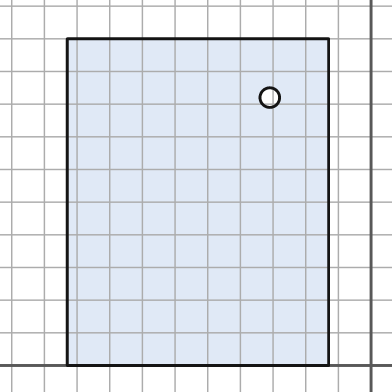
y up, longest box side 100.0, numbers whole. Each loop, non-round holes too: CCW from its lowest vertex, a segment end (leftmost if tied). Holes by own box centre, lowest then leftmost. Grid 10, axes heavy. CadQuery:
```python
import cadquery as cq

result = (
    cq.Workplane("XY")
    .moveTo(-93.0, 0.0)
    .lineTo(-13.0, 0.0)
    .lineTo(-13.0, 100.0)
    .lineTo(-93.0, 100.0)
    .close()
    .moveTo(-31.0, 82.0)
    .circle(3.0)
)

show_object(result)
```